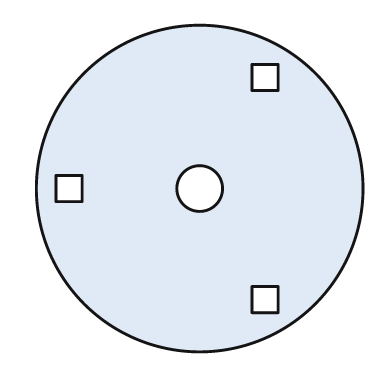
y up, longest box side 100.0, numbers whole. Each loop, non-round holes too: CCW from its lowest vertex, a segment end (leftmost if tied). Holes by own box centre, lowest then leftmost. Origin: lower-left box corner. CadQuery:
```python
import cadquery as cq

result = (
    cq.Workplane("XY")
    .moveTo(50.0, 50.0)
    .circle(50.0)
    .moveTo(66.0, 12.0)
    .lineTo(74.0, 12.0)
    .lineTo(74.0, 20.0)
    .lineTo(66.0, 20.0)
    .close()
    .moveTo(6.0, 46.0)
    .lineTo(14.0, 46.0)
    .lineTo(14.0, 54.0)
    .lineTo(6.0, 54.0)
    .close()
    .moveTo(50.0, 50.0)
    .circle(7.0)
    .moveTo(66.0, 80.0)
    .lineTo(74.0, 80.0)
    .lineTo(74.0, 88.0)
    .lineTo(66.0, 88.0)
    .close()
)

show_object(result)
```